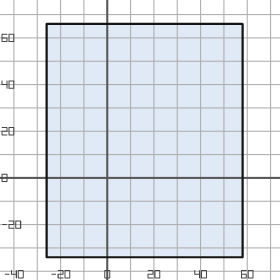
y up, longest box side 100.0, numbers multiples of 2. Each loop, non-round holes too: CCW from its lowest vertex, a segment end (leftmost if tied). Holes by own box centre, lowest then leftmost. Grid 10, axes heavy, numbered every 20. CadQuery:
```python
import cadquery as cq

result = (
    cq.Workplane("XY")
    .moveTo(-26.0, -34.0)
    .lineTo(58.0, -34.0)
    .lineTo(58.0, 66.0)
    .lineTo(-26.0, 66.0)
    .close()
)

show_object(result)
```